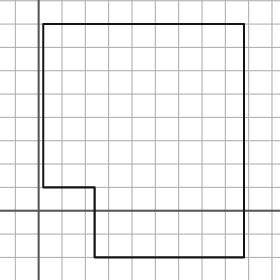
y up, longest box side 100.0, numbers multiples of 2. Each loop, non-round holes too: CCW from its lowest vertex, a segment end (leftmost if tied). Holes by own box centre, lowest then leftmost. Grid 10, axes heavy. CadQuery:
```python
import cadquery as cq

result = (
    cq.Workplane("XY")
    .moveTo(24.0, -20.0)
    .lineTo(88.0, -20.0)
    .lineTo(88.0, 80.0)
    .lineTo(2.0, 80.0)
    .lineTo(2.0, 10.0)
    .lineTo(24.0, 10.0)
    .close()
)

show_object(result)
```